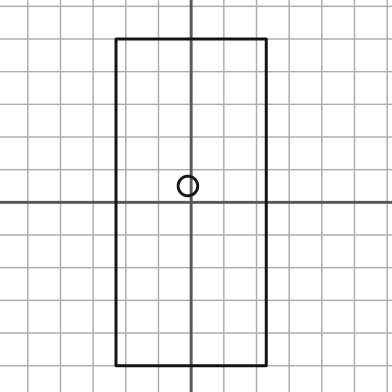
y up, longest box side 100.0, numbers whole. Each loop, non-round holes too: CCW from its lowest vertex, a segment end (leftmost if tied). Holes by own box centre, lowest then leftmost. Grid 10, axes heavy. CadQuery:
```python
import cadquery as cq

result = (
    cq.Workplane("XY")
    .moveTo(-23.0, -50.0)
    .lineTo(23.0, -50.0)
    .lineTo(23.0, 50.0)
    .lineTo(-23.0, 50.0)
    .close()
    .moveTo(-1.0, 5.0)
    .circle(3.0)
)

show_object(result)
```